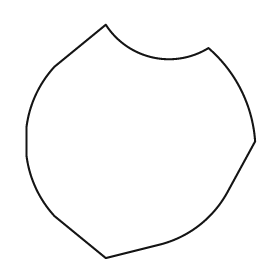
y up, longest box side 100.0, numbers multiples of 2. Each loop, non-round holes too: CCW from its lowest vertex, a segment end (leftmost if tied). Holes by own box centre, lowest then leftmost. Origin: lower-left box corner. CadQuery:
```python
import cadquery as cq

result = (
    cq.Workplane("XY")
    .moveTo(34.0, 0.0)
    .lineTo(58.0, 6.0)
    .threePointArc((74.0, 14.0), (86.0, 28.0))
    .lineTo(98.0, 50.0)
    .threePointArc((92.0, 72.0), (78.0, 90.0))
    .threePointArc((54.0, 86.0), (34.0, 100.0))
    .lineTo(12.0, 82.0)
    .threePointArc((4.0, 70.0), (0.0, 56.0))
    .lineTo(0.0, 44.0)
    .threePointArc((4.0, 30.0), (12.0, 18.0))
    .close()
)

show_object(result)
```